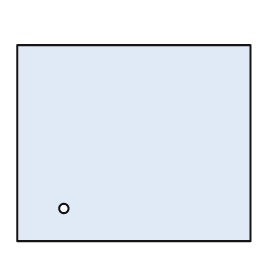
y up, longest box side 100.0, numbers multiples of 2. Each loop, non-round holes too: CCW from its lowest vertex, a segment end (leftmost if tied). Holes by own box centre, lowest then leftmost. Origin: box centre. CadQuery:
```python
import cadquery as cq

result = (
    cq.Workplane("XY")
    .moveTo(-50.0, -42.0)
    .lineTo(50.0, -42.0)
    .lineTo(50.0, 42.0)
    .lineTo(-50.0, 42.0)
    .close()
    .moveTo(-30.0, -28.0)
    .circle(2.0)
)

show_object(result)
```